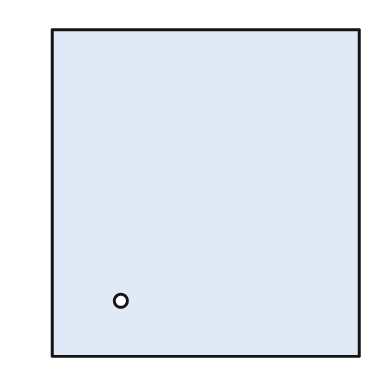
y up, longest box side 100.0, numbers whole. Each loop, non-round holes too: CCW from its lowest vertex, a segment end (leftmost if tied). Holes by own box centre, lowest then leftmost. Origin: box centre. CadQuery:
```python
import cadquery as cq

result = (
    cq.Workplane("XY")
    .moveTo(-47.0, -50.0)
    .lineTo(47.0, -50.0)
    .lineTo(47.0, 50.0)
    .lineTo(-47.0, 50.0)
    .close()
    .moveTo(-26.0, -33.0)
    .circle(2.0)
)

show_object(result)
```